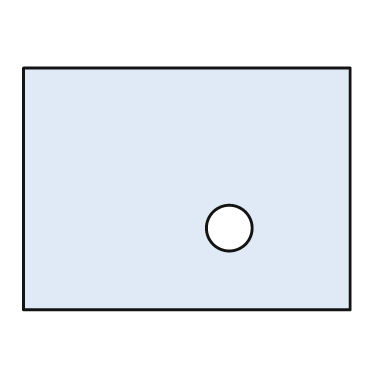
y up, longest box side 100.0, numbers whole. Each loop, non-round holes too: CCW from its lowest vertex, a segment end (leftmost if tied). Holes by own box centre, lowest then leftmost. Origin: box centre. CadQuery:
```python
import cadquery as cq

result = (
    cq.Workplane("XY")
    .moveTo(-50.0, -37.0)
    .lineTo(50.0, -37.0)
    .lineTo(50.0, 37.0)
    .lineTo(-50.0, 37.0)
    .close()
    .moveTo(13.0, -12.0)
    .circle(7.0)
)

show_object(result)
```